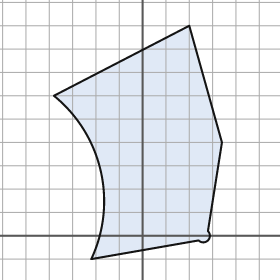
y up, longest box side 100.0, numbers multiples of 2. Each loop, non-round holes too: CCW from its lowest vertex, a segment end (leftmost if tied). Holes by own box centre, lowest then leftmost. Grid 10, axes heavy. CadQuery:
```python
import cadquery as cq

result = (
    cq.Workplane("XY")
    .moveTo(-22.0, -10.0)
    .lineTo(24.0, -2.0)
    .threePointArc((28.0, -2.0), (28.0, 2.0))
    .lineTo(34.0, 40.0)
    .lineTo(20.0, 90.0)
    .lineTo(-38.0, 60.0)
    .threePointArc((-18.0, 28.0), (-22.0, -10.0))
    .close()
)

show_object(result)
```